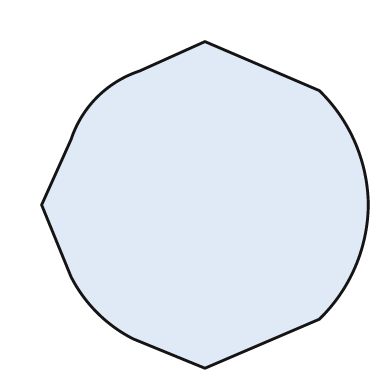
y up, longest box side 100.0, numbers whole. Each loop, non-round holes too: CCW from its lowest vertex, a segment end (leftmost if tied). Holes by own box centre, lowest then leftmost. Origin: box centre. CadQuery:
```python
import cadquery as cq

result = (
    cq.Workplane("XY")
    .moveTo(0.0, -50.0)
    .lineTo(35.0, -35.0)
    .threePointArc((46.0, -19.0), (50.0, 0.0))
    .threePointArc((46.0, 19.0), (35.0, 35.0))
    .lineTo(0.0, 50.0)
    .lineTo(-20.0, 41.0)
    .threePointArc((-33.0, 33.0), (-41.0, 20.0))
    .lineTo(-50.0, 0.0)
    .lineTo(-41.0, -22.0)
    .threePointArc((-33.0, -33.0), (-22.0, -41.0))
    .close()
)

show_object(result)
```